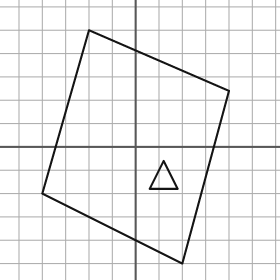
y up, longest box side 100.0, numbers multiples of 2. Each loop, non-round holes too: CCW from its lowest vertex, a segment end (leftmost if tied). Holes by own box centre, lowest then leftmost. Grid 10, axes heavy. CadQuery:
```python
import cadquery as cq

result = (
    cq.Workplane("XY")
    .moveTo(20.0, -50.0)
    .lineTo(40.0, 24.0)
    .lineTo(-20.0, 50.0)
    .lineTo(-40.0, -20.0)
    .close()
    .moveTo(6.0, -18.0)
    .lineTo(18.0, -18.0)
    .lineTo(12.0, -6.0)
    .close()
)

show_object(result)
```